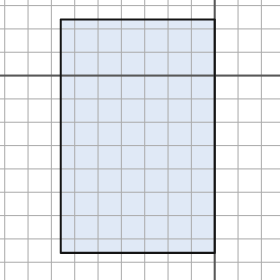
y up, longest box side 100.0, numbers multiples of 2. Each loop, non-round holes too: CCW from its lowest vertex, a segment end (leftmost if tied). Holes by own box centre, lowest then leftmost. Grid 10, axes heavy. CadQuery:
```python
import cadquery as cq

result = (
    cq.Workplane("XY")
    .moveTo(-66.0, -76.0)
    .lineTo(0.0, -76.0)
    .lineTo(0.0, 24.0)
    .lineTo(-66.0, 24.0)
    .close()
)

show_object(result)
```